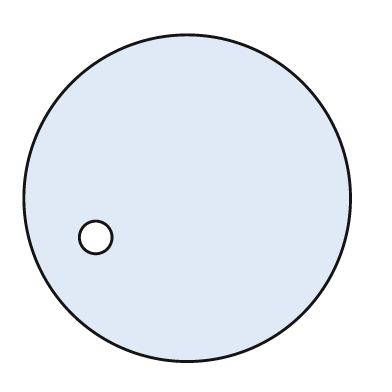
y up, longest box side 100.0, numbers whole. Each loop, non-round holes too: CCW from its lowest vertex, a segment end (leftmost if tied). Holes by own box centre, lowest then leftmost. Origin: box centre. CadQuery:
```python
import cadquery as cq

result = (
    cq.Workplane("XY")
    .moveTo(0.0, 0.0)
    .circle(50.0)
    .moveTo(-28.0, -12.0)
    .circle(5.0)
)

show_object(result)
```